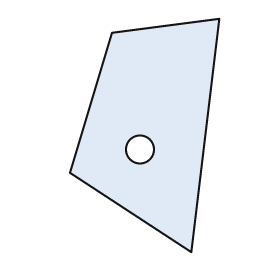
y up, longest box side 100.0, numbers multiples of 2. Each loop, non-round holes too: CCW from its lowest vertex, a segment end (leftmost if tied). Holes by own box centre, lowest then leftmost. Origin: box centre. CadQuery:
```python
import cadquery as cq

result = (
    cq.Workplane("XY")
    .moveTo(20.0, -50.0)
    .lineTo(32.0, 50.0)
    .lineTo(-14.0, 44.0)
    .lineTo(-32.0, -16.0)
    .close()
    .moveTo(-2.0, -6.0)
    .circle(6.0)
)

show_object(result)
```